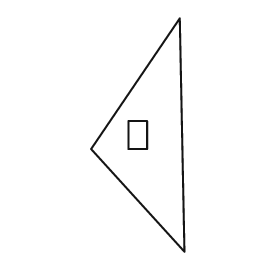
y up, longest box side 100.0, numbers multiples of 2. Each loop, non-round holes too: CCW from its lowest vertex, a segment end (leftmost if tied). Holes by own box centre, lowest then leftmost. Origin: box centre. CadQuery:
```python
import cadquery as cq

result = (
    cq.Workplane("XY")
    .moveTo(20.0, -50.0)
    .lineTo(18.0, 50.0)
    .lineTo(-20.0, -6.0)
    .close()
    .moveTo(-4.0, -6.0)
    .lineTo(4.0, -6.0)
    .lineTo(4.0, 6.0)
    .lineTo(-4.0, 6.0)
    .close()
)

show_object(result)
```